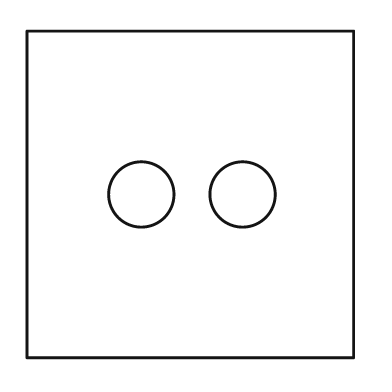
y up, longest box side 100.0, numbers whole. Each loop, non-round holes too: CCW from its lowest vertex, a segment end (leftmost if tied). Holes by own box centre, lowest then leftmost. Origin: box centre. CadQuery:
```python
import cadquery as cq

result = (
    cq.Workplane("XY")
    .moveTo(-50.0, -50.0)
    .lineTo(50.0, -50.0)
    .lineTo(50.0, 50.0)
    .lineTo(-50.0, 50.0)
    .close()
    .moveTo(-15.0, 0.0)
    .circle(10.0)
    .moveTo(16.0, 0.0)
    .circle(10.0)
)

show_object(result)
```